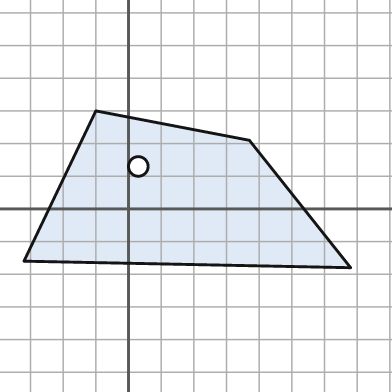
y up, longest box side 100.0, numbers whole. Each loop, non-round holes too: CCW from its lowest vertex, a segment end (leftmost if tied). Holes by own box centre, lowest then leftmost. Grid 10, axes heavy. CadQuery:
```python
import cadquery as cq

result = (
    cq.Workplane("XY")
    .moveTo(68.0, -18.0)
    .lineTo(37.0, 21.0)
    .lineTo(-10.0, 30.0)
    .lineTo(-32.0, -16.0)
    .close()
    .moveTo(3.0, 13.0)
    .circle(3.0)
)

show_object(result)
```